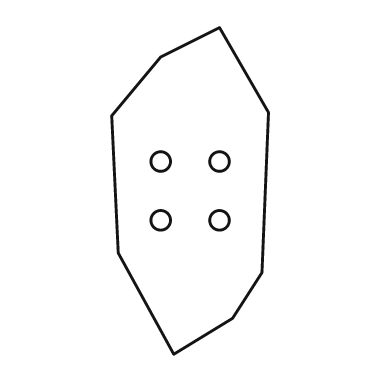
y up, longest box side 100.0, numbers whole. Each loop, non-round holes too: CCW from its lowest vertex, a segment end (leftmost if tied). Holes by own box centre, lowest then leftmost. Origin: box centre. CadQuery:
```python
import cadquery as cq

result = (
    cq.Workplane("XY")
    .moveTo(-5.0, -50.0)
    .lineTo(13.0, -39.0)
    .lineTo(22.0, -25.0)
    .lineTo(24.0, 24.0)
    .lineTo(9.0, 50.0)
    .lineTo(-9.0, 41.0)
    .lineTo(-24.0, 23.0)
    .lineTo(-22.0, -19.0)
    .close()
    .moveTo(-9.0, -9.0)
    .circle(3.0)
    .moveTo(9.0, -9.0)
    .circle(3.0)
    .moveTo(-9.0, 9.0)
    .circle(3.0)
    .moveTo(9.0, 9.0)
    .circle(3.0)
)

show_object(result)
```